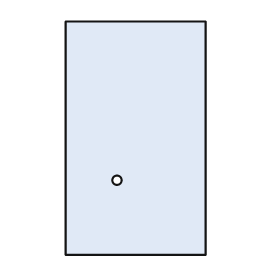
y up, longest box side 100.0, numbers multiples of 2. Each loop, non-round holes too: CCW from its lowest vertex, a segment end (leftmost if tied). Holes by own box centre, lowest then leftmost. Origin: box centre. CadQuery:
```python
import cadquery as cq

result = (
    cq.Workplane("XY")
    .moveTo(-30.0, -50.0)
    .lineTo(30.0, -50.0)
    .lineTo(30.0, 50.0)
    .lineTo(-30.0, 50.0)
    .close()
    .moveTo(-8.0, -18.0)
    .circle(2.0)
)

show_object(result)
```